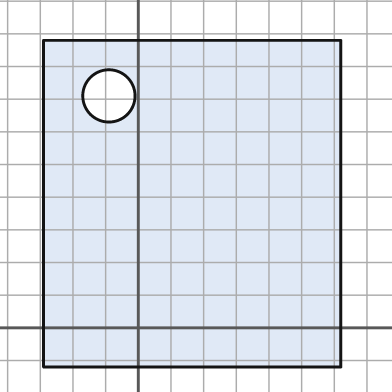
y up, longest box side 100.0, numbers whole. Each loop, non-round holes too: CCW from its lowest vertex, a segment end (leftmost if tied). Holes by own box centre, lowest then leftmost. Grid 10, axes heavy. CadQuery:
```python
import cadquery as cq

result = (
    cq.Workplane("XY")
    .moveTo(-29.0, -12.0)
    .lineTo(62.0, -12.0)
    .lineTo(62.0, 88.0)
    .lineTo(-29.0, 88.0)
    .close()
    .moveTo(-9.0, 71.0)
    .circle(8.0)
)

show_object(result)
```